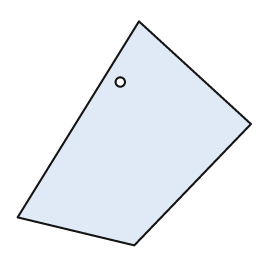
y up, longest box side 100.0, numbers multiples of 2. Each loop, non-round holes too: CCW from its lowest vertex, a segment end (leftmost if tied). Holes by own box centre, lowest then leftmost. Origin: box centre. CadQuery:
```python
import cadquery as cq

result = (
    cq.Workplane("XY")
    .moveTo(0.0, -48.0)
    .lineTo(50.0, 4.0)
    .lineTo(2.0, 48.0)
    .lineTo(-50.0, -36.0)
    .close()
    .moveTo(-6.0, 22.0)
    .circle(2.0)
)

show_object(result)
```